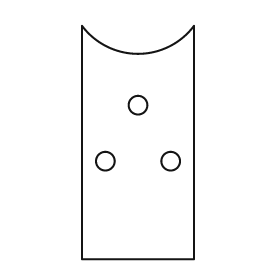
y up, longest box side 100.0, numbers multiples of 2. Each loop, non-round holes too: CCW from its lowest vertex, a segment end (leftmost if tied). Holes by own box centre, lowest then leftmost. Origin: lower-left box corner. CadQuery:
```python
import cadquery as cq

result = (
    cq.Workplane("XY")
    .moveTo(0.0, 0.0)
    .lineTo(48.0, 0.0)
    .lineTo(48.0, 100.0)
    .threePointArc((24.0, 88.0), (0.0, 100.0))
    .close()
    .moveTo(10.0, 42.0)
    .circle(4.0)
    .moveTo(38.0, 42.0)
    .circle(4.0)
    .moveTo(24.0, 66.0)
    .circle(4.0)
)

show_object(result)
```